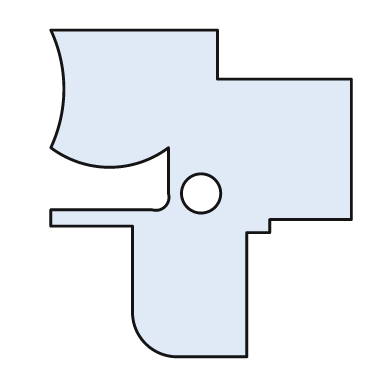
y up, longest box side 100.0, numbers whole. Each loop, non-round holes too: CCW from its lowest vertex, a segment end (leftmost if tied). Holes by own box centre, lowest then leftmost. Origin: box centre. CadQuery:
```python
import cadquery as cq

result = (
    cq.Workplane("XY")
    .moveTo(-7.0, -50.0)
    .lineTo(14.0, -50.0)
    .lineTo(14.0, -12.0)
    .lineTo(21.0, -12.0)
    .lineTo(21.0, -8.0)
    .lineTo(46.0, -8.0)
    .lineTo(46.0, 35.0)
    .lineTo(5.0, 35.0)
    .lineTo(5.0, 50.0)
    .lineTo(-46.0, 50.0)
    .threePointArc((-42.0, 32.0), (-46.0, 14.0))
    .threePointArc((-28.0, 8.0), (-10.0, 14.0))
    .lineTo(-10.0, 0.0)
    .threePointArc((-11.0, -4.0), (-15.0, -5.0))
    .lineTo(-46.0, -5.0)
    .lineTo(-46.0, -10.0)
    .lineTo(-21.0, -10.0)
    .lineTo(-21.0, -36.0)
    .threePointArc((-17.0, -46.0), (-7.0, -50.0))
    .close()
    .moveTo(0.0, 0.0)
    .circle(6.0)
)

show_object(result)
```